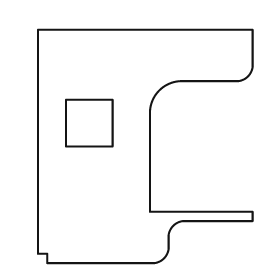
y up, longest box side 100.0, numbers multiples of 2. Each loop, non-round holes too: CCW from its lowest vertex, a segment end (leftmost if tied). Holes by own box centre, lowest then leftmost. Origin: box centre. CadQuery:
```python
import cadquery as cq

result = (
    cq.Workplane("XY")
    .moveTo(-42.0, -50.0)
    .lineTo(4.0, -50.0)
    .threePointArc((8.0, -48.0), (10.0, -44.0))
    .lineTo(10.0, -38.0)
    .threePointArc((12.0, -34.0), (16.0, -32.0))
    .lineTo(46.0, -32.0)
    .lineTo(46.0, -28.0)
    .lineTo(2.0, -28.0)
    .lineTo(2.0, 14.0)
    .threePointArc((6.0, 24.0), (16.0, 28.0))
    .lineTo(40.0, 28.0)
    .threePointArc((44.0, 30.0), (46.0, 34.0))
    .lineTo(46.0, 50.0)
    .lineTo(-46.0, 50.0)
    .lineTo(-46.0, -46.0)
    .lineTo(-42.0, -46.0)
    .close()
    .moveTo(-34.0, 0.0)
    .lineTo(-14.0, 0.0)
    .lineTo(-14.0, 20.0)
    .lineTo(-34.0, 20.0)
    .close()
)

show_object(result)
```